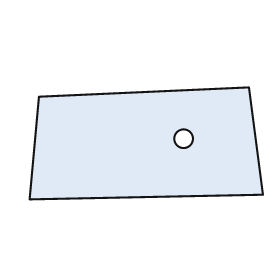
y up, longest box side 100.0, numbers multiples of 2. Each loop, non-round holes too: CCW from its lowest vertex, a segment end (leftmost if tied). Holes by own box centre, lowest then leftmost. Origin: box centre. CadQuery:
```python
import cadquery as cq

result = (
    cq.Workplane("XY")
    .moveTo(-50.0, -24.0)
    .lineTo(50.0, -22.0)
    .lineTo(44.0, 24.0)
    .lineTo(-46.0, 20.0)
    .close()
    .moveTo(16.0, 2.0)
    .circle(4.0)
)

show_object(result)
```